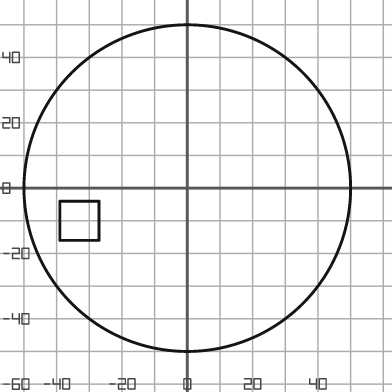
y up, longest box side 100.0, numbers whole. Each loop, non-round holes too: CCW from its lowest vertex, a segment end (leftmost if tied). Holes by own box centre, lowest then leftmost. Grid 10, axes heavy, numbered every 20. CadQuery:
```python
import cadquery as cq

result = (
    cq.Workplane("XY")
    .moveTo(0.0, 0.0)
    .circle(50.0)
    .moveTo(-39.0, -16.0)
    .lineTo(-27.0, -16.0)
    .lineTo(-27.0, -4.0)
    .lineTo(-39.0, -4.0)
    .close()
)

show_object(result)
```